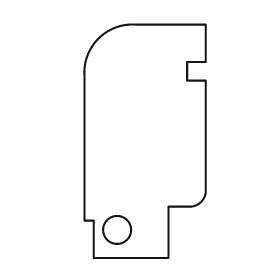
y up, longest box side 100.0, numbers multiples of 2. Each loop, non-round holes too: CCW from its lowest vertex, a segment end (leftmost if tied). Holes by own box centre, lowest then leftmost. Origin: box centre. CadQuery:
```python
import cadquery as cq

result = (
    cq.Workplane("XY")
    .moveTo(-22.0, -50.0)
    .lineTo(10.0, -50.0)
    .lineTo(10.0, -28.0)
    .lineTo(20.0, -28.0)
    .threePointArc((24.0, -26.0), (26.0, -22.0))
    .lineTo(26.0, 26.0)
    .lineTo(18.0, 26.0)
    .lineTo(18.0, 34.0)
    .lineTo(26.0, 34.0)
    .lineTo(26.0, 50.0)
    .lineTo(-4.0, 50.0)
    .threePointArc((-20.0, 44.0), (-26.0, 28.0))
    .lineTo(-26.0, -34.0)
    .lineTo(-22.0, -34.0)
    .close()
    .moveTo(-12.0, -38.0)
    .circle(6.0)
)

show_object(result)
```